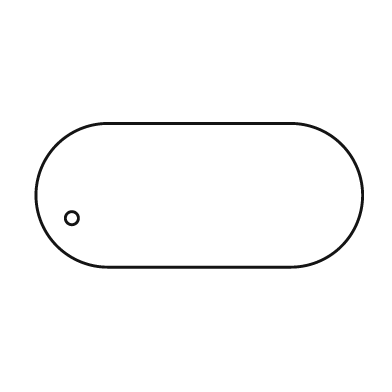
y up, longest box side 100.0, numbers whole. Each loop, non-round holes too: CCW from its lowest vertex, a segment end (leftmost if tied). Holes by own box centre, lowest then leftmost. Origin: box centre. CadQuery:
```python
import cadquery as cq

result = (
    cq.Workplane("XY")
    .moveTo(-28.0, -22.0)
    .lineTo(28.0, -22.0)
    .threePointArc((50.0, 0.0), (28.0, 22.0))
    .lineTo(-28.0, 22.0)
    .threePointArc((-50.0, 0.0), (-28.0, -22.0))
    .close()
    .moveTo(-39.0, -7.0)
    .circle(2.0)
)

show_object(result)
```